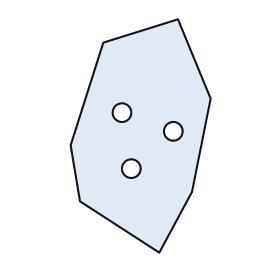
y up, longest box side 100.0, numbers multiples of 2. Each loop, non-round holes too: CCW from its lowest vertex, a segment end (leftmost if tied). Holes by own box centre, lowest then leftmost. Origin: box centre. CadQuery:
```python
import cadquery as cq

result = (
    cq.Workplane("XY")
    .moveTo(8.0, -50.0)
    .lineTo(22.0, -24.0)
    .lineTo(30.0, 16.0)
    .lineTo(16.0, 50.0)
    .lineTo(-16.0, 40.0)
    .lineTo(-30.0, -4.0)
    .lineTo(-26.0, -28.0)
    .close()
    .moveTo(-4.0, -14.0)
    .circle(4.0)
    .moveTo(14.0, 2.0)
    .circle(4.0)
    .moveTo(-8.0, 10.0)
    .circle(4.0)
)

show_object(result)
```